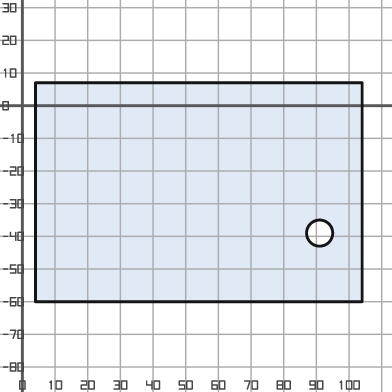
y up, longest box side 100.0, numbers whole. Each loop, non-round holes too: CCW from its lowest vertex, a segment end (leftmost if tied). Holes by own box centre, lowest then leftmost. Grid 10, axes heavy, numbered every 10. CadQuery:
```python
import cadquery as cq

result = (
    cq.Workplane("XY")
    .moveTo(4.0, -60.0)
    .lineTo(104.0, -60.0)
    .lineTo(104.0, 7.0)
    .lineTo(4.0, 7.0)
    .close()
    .moveTo(91.0, -39.0)
    .circle(4.0)
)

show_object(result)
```